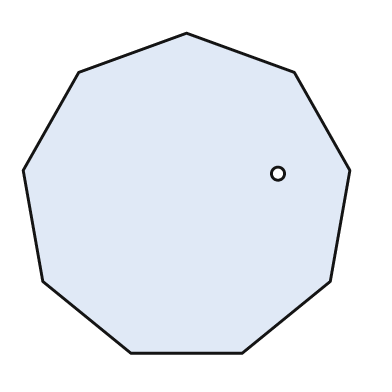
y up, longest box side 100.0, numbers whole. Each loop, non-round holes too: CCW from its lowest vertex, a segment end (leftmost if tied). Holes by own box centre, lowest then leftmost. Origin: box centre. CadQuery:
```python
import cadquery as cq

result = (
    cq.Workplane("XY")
    .moveTo(-17.0, -49.0)
    .lineTo(17.0, -49.0)
    .lineTo(44.0, -27.0)
    .lineTo(50.0, 7.0)
    .lineTo(33.0, 37.0)
    .lineTo(0.0, 49.0)
    .lineTo(-33.0, 37.0)
    .lineTo(-50.0, 7.0)
    .lineTo(-44.0, -27.0)
    .close()
    .moveTo(28.0, 6.0)
    .circle(2.0)
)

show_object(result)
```